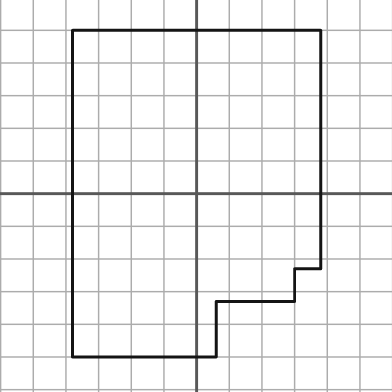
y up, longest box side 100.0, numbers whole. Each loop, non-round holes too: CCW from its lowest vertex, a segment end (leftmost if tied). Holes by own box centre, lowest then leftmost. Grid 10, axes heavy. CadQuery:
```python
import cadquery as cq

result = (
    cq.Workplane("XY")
    .moveTo(-38.0, -50.0)
    .lineTo(6.0, -50.0)
    .lineTo(6.0, -33.0)
    .lineTo(30.0, -33.0)
    .lineTo(30.0, -23.0)
    .lineTo(38.0, -23.0)
    .lineTo(38.0, 50.0)
    .lineTo(-38.0, 50.0)
    .close()
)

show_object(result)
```